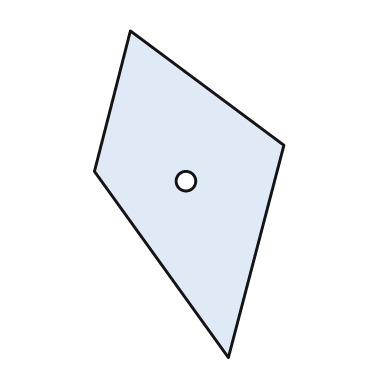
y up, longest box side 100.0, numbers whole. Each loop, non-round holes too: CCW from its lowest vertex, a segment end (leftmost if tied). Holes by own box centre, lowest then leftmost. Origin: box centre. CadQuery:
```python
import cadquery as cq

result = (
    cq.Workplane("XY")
    .moveTo(12.0, -50.0)
    .lineTo(29.0, 15.0)
    .lineTo(-18.0, 50.0)
    .lineTo(-29.0, 7.0)
    .close()
    .moveTo(-1.0, 4.0)
    .circle(3.0)
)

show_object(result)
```